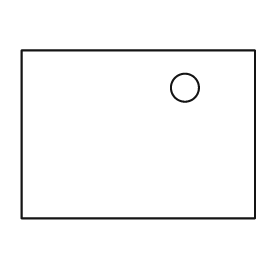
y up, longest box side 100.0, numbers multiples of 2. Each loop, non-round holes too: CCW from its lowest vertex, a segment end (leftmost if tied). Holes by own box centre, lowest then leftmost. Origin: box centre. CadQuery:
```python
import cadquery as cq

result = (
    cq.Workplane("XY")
    .moveTo(-50.0, -36.0)
    .lineTo(50.0, -36.0)
    .lineTo(50.0, 36.0)
    .lineTo(-50.0, 36.0)
    .close()
    .moveTo(20.0, 20.0)
    .circle(6.0)
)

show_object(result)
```